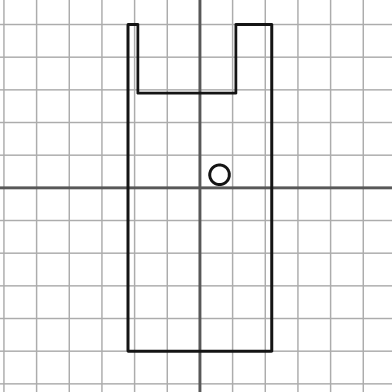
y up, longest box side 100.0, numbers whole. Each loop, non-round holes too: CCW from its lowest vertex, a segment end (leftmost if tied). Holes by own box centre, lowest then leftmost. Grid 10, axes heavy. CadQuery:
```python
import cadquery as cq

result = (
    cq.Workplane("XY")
    .moveTo(-22.0, -50.0)
    .lineTo(22.0, -50.0)
    .lineTo(22.0, 50.0)
    .lineTo(11.0, 50.0)
    .lineTo(11.0, 29.0)
    .lineTo(-19.0, 29.0)
    .lineTo(-19.0, 50.0)
    .lineTo(-22.0, 50.0)
    .close()
    .moveTo(6.0, 4.0)
    .circle(3.0)
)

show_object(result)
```